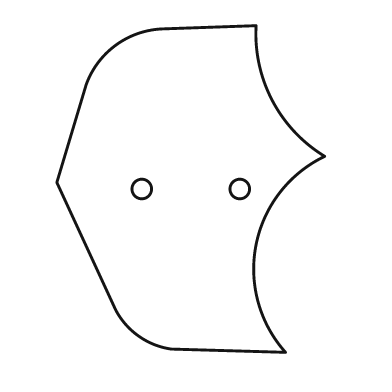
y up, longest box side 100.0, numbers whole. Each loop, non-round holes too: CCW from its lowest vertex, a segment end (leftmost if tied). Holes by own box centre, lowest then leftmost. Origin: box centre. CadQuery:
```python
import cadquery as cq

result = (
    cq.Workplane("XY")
    .moveTo(29.0, -50.0)
    .threePointArc((20.0, -17.0), (41.0, 10.0))
    .threePointArc((25.0, 27.0), (20.0, 50.0))
    .lineTo(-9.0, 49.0)
    .threePointArc((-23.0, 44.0), (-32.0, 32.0))
    .lineTo(-41.0, 2.0)
    .lineTo(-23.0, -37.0)
    .threePointArc((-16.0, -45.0), (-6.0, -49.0))
    .close()
    .moveTo(-15.0, 0.0)
    .circle(3.0)
    .moveTo(15.0, 0.0)
    .circle(3.0)
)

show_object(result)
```